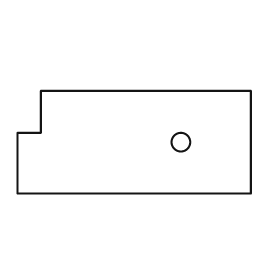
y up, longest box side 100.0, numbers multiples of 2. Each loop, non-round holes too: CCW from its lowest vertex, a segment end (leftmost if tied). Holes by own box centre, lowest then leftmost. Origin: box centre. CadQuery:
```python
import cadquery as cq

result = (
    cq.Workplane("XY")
    .moveTo(-50.0, -22.0)
    .lineTo(50.0, -22.0)
    .lineTo(50.0, 22.0)
    .lineTo(-40.0, 22.0)
    .lineTo(-40.0, 4.0)
    .lineTo(-50.0, 4.0)
    .close()
    .moveTo(20.0, 0.0)
    .circle(4.0)
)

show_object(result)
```